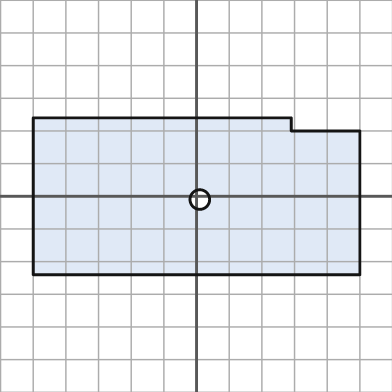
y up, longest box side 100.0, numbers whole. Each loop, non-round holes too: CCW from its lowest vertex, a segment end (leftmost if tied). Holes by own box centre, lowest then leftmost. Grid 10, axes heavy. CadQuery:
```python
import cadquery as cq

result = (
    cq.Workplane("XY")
    .moveTo(-50.0, -24.0)
    .lineTo(50.0, -24.0)
    .lineTo(50.0, 20.0)
    .lineTo(29.0, 20.0)
    .lineTo(29.0, 24.0)
    .lineTo(-50.0, 24.0)
    .close()
    .moveTo(1.0, -1.0)
    .circle(3.0)
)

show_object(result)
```